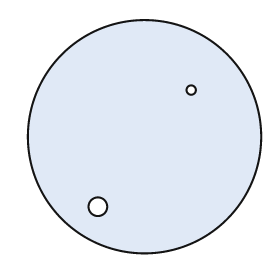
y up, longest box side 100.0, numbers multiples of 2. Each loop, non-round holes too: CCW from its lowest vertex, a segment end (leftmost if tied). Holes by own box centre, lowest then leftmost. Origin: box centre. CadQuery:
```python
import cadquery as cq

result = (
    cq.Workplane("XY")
    .moveTo(0.0, 0.0)
    .circle(50.0)
    .moveTo(-20.0, -30.0)
    .circle(4.0)
    .moveTo(20.0, 20.0)
    .circle(2.0)
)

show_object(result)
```